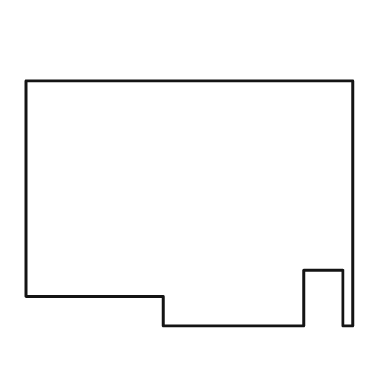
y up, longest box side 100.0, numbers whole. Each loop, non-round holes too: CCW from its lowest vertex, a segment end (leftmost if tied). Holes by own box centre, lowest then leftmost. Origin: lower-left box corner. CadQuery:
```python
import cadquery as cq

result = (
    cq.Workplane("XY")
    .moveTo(42.0, 0.0)
    .lineTo(85.0, 0.0)
    .lineTo(85.0, 17.0)
    .lineTo(97.0, 17.0)
    .lineTo(97.0, 0.0)
    .lineTo(100.0, 0.0)
    .lineTo(100.0, 75.0)
    .lineTo(0.0, 75.0)
    .lineTo(0.0, 9.0)
    .lineTo(42.0, 9.0)
    .close()
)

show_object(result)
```